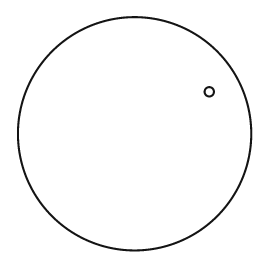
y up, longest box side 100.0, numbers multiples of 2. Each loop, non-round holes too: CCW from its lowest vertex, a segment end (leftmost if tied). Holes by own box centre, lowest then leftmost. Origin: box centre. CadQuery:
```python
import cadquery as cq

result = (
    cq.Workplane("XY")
    .moveTo(0.0, 0.0)
    .circle(50.0)
    .moveTo(32.0, 18.0)
    .circle(2.0)
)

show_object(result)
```